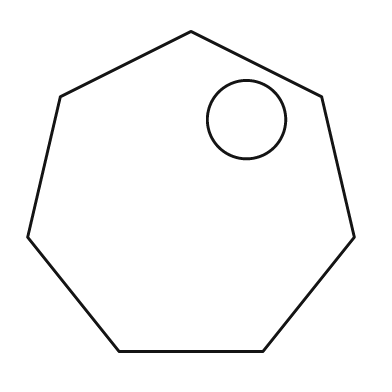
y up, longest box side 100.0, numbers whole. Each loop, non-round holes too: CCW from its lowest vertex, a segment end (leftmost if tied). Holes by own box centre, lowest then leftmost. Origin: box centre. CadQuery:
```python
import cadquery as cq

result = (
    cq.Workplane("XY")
    .moveTo(-22.0, -49.0)
    .lineTo(22.0, -49.0)
    .lineTo(50.0, -14.0)
    .lineTo(40.0, 29.0)
    .lineTo(0.0, 49.0)
    .lineTo(-40.0, 29.0)
    .lineTo(-50.0, -14.0)
    .close()
    .moveTo(17.0, 22.0)
    .circle(12.0)
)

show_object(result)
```